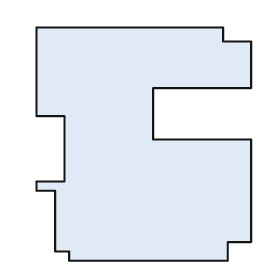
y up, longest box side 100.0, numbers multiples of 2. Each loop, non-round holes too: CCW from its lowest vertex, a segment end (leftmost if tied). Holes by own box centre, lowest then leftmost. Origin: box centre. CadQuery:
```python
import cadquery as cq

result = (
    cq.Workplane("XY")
    .moveTo(-32.0, -50.0)
    .lineTo(36.0, -50.0)
    .lineTo(36.0, -42.0)
    .lineTo(46.0, -42.0)
    .lineTo(46.0, 2.0)
    .lineTo(4.0, 2.0)
    .lineTo(4.0, 24.0)
    .lineTo(46.0, 24.0)
    .lineTo(46.0, 44.0)
    .lineTo(34.0, 44.0)
    .lineTo(34.0, 50.0)
    .lineTo(-46.0, 50.0)
    .lineTo(-46.0, 12.0)
    .lineTo(-34.0, 12.0)
    .lineTo(-34.0, -16.0)
    .lineTo(-46.0, -16.0)
    .lineTo(-46.0, -20.0)
    .lineTo(-38.0, -20.0)
    .lineTo(-38.0, -46.0)
    .lineTo(-32.0, -46.0)
    .close()
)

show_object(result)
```